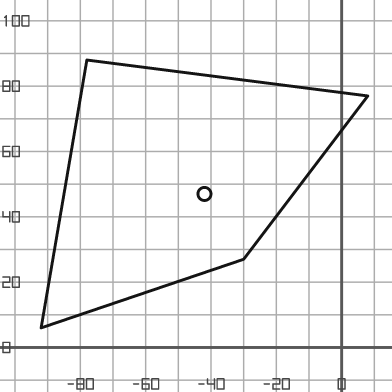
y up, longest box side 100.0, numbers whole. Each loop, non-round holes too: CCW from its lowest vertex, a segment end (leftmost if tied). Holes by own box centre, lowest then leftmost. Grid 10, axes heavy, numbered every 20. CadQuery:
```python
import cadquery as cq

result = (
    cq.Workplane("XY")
    .moveTo(-92.0, 6.0)
    .lineTo(-30.0, 27.0)
    .lineTo(8.0, 77.0)
    .lineTo(-78.0, 88.0)
    .close()
    .moveTo(-42.0, 47.0)
    .circle(2.0)
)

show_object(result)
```